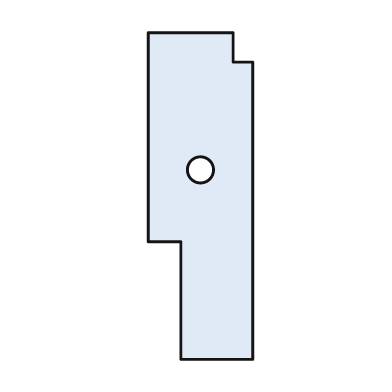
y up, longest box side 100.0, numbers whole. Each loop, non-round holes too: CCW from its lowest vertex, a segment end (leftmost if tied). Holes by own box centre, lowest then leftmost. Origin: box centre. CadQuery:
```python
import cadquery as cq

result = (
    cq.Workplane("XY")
    .moveTo(-6.0, -50.0)
    .lineTo(16.0, -50.0)
    .lineTo(16.0, 41.0)
    .lineTo(10.0, 41.0)
    .lineTo(10.0, 50.0)
    .lineTo(-16.0, 50.0)
    .lineTo(-16.0, -14.0)
    .lineTo(-6.0, -14.0)
    .close()
    .moveTo(0.0, 8.0)
    .circle(4.0)
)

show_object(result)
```